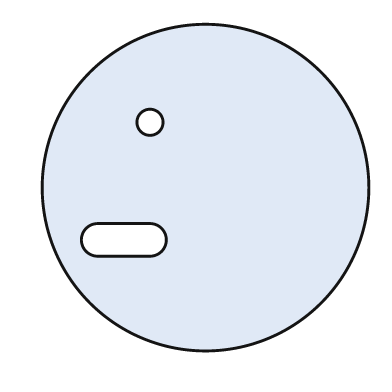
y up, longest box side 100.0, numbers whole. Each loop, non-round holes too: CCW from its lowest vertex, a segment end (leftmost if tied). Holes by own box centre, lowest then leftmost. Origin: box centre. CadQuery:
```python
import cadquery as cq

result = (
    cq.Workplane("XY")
    .moveTo(0.0, 0.0)
    .circle(50.0)
    .moveTo(-33.0, -21.0)
    .lineTo(-17.0, -21.0)
    .threePointArc((-12.0, -16.0), (-17.0, -11.0))
    .lineTo(-33.0, -11.0)
    .threePointArc((-38.0, -16.0), (-33.0, -21.0))
    .close()
    .moveTo(-17.0, 20.0)
    .circle(4.0)
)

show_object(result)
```